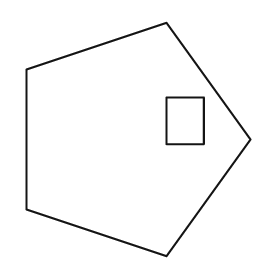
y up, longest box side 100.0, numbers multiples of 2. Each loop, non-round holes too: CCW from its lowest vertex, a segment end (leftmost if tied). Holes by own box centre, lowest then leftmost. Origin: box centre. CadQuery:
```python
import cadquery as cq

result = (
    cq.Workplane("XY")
    .moveTo(12.0, -50.0)
    .lineTo(48.0, 0.0)
    .lineTo(12.0, 50.0)
    .lineTo(-48.0, 30.0)
    .lineTo(-48.0, -30.0)
    .close()
    .moveTo(12.0, -2.0)
    .lineTo(28.0, -2.0)
    .lineTo(28.0, 18.0)
    .lineTo(12.0, 18.0)
    .close()
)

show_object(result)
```